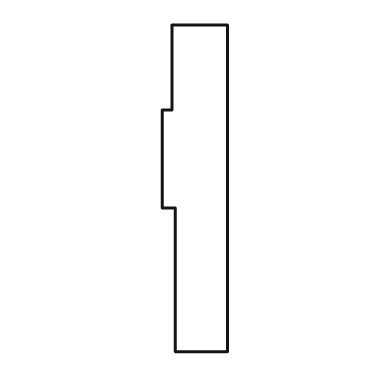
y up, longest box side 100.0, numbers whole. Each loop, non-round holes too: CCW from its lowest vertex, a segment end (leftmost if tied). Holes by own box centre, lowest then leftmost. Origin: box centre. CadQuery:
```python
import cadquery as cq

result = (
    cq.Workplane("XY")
    .moveTo(-6.0, -50.0)
    .lineTo(10.0, -50.0)
    .lineTo(10.0, 50.0)
    .lineTo(-7.0, 50.0)
    .lineTo(-7.0, 24.0)
    .lineTo(-10.0, 24.0)
    .lineTo(-10.0, -6.0)
    .lineTo(-6.0, -6.0)
    .close()
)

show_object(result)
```